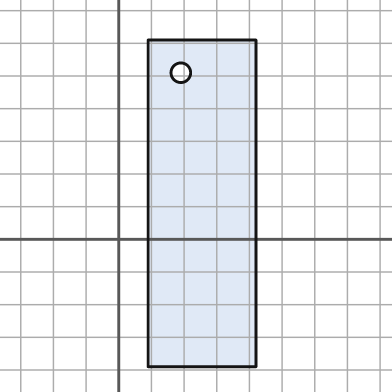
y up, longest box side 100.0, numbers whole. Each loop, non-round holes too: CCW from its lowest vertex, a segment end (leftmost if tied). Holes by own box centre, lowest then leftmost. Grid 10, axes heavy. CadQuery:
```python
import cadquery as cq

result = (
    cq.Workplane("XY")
    .moveTo(9.0, -39.0)
    .lineTo(42.0, -39.0)
    .lineTo(42.0, 61.0)
    .lineTo(9.0, 61.0)
    .close()
    .moveTo(19.0, 51.0)
    .circle(3.0)
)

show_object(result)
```